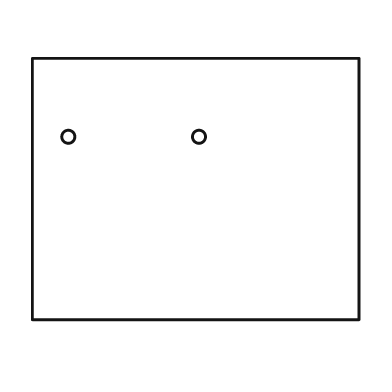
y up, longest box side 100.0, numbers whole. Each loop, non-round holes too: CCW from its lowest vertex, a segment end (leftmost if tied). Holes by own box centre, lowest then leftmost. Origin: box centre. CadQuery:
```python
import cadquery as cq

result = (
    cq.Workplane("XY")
    .moveTo(-50.0, -40.0)
    .lineTo(50.0, -40.0)
    .lineTo(50.0, 40.0)
    .lineTo(-50.0, 40.0)
    .close()
    .moveTo(-39.0, 16.0)
    .circle(2.0)
    .moveTo(1.0, 16.0)
    .circle(2.0)
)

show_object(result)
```